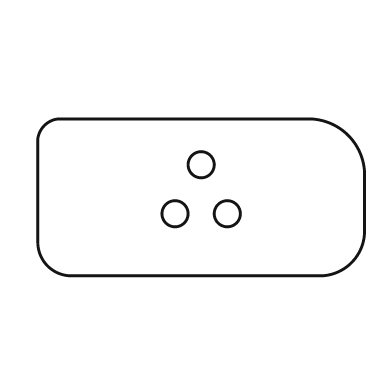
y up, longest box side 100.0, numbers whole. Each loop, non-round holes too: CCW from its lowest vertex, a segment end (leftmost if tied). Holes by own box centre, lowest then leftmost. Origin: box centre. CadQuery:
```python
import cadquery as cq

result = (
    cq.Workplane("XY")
    .moveTo(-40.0, -24.0)
    .lineTo(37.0, -24.0)
    .threePointArc((46.0, -20.0), (50.0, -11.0))
    .lineTo(50.0, 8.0)
    .threePointArc((45.0, 19.0), (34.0, 24.0))
    .lineTo(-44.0, 24.0)
    .threePointArc((-48.0, 22.0), (-50.0, 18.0))
    .lineTo(-50.0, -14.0)
    .threePointArc((-47.0, -21.0), (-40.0, -24.0))
    .close()
    .moveTo(-8.0, -5.0)
    .circle(4.0)
    .moveTo(8.0, -5.0)
    .circle(4.0)
    .moveTo(0.0, 10.0)
    .circle(4.0)
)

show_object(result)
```